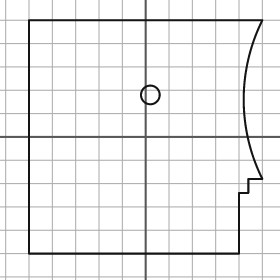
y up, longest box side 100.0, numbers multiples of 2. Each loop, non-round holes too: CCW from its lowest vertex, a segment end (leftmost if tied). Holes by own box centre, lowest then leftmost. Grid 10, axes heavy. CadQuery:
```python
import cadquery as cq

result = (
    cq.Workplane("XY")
    .moveTo(-50.0, -50.0)
    .lineTo(40.0, -50.0)
    .lineTo(40.0, -24.0)
    .lineTo(44.0, -24.0)
    .lineTo(44.0, -18.0)
    .lineTo(50.0, -18.0)
    .threePointArc((42.0, 16.0), (50.0, 50.0))
    .lineTo(-50.0, 50.0)
    .close()
    .moveTo(2.0, 18.0)
    .circle(4.0)
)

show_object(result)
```